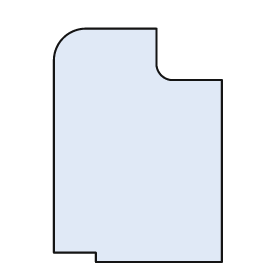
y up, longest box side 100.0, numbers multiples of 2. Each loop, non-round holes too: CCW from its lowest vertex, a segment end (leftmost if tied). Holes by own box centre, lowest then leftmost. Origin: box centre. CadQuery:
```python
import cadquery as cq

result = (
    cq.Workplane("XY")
    .moveTo(-18.0, -50.0)
    .lineTo(36.0, -50.0)
    .lineTo(36.0, 28.0)
    .lineTo(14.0, 28.0)
    .threePointArc((10.0, 30.0), (8.0, 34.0))
    .lineTo(8.0, 50.0)
    .lineTo(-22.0, 50.0)
    .threePointArc((-32.0, 46.0), (-36.0, 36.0))
    .lineTo(-36.0, -46.0)
    .lineTo(-18.0, -46.0)
    .close()
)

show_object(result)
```